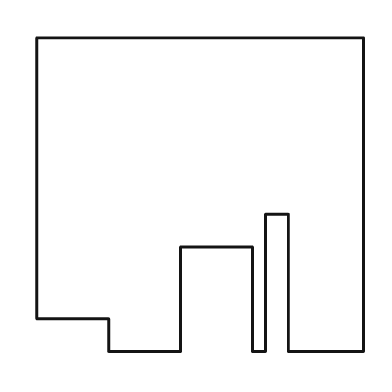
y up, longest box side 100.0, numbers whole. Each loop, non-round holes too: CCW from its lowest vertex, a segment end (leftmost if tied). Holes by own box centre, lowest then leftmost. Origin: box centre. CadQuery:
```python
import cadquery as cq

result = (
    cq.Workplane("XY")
    .moveTo(-28.0, -48.0)
    .lineTo(-6.0, -48.0)
    .lineTo(-6.0, -16.0)
    .lineTo(16.0, -16.0)
    .lineTo(16.0, -48.0)
    .lineTo(20.0, -48.0)
    .lineTo(20.0, -6.0)
    .lineTo(27.0, -6.0)
    .lineTo(27.0, -48.0)
    .lineTo(50.0, -48.0)
    .lineTo(50.0, 48.0)
    .lineTo(-50.0, 48.0)
    .lineTo(-50.0, -38.0)
    .lineTo(-28.0, -38.0)
    .close()
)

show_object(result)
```